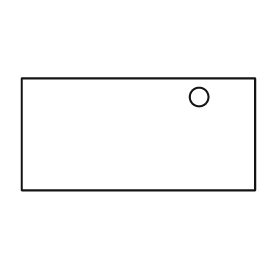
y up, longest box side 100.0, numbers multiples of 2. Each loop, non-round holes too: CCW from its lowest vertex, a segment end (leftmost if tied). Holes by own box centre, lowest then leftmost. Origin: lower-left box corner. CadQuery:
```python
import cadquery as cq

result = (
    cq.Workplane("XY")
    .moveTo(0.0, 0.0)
    .lineTo(100.0, 0.0)
    .lineTo(100.0, 48.0)
    .lineTo(0.0, 48.0)
    .close()
    .moveTo(76.0, 40.0)
    .circle(4.0)
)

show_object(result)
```